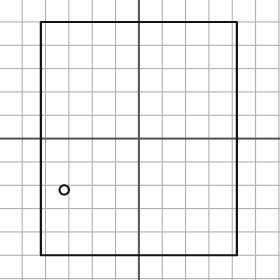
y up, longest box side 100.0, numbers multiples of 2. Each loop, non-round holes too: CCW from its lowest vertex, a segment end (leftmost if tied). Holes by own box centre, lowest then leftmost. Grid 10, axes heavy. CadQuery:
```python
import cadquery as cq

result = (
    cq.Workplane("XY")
    .moveTo(-42.0, -50.0)
    .lineTo(42.0, -50.0)
    .lineTo(42.0, 50.0)
    .lineTo(-42.0, 50.0)
    .close()
    .moveTo(-32.0, -22.0)
    .circle(2.0)
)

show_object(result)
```